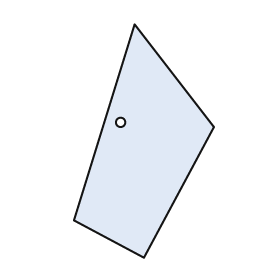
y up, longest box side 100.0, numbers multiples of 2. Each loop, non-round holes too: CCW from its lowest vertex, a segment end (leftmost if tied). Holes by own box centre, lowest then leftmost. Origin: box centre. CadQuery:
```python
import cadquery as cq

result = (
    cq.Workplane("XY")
    .moveTo(0.0, -50.0)
    .lineTo(30.0, 6.0)
    .lineTo(-4.0, 50.0)
    .lineTo(-30.0, -34.0)
    .close()
    .moveTo(-10.0, 8.0)
    .circle(2.0)
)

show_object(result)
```